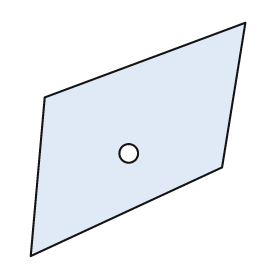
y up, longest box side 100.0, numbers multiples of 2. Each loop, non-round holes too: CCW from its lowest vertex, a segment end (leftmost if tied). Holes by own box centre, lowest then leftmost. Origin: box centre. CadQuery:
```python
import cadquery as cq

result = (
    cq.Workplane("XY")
    .moveTo(-46.0, -50.0)
    .lineTo(36.0, -12.0)
    .lineTo(46.0, 50.0)
    .lineTo(-40.0, 18.0)
    .close()
    .moveTo(-4.0, -6.0)
    .circle(4.0)
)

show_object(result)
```